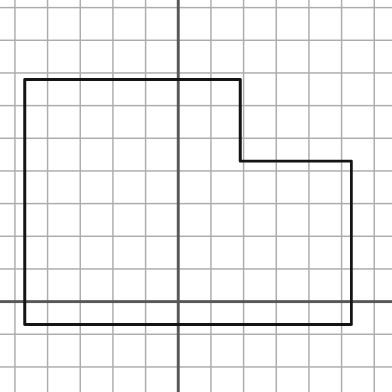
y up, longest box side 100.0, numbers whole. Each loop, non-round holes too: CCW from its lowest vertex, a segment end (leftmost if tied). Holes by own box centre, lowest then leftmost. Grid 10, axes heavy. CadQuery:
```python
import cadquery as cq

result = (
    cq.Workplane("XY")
    .moveTo(-47.0, -7.0)
    .lineTo(53.0, -7.0)
    .lineTo(53.0, 43.0)
    .lineTo(19.0, 43.0)
    .lineTo(19.0, 68.0)
    .lineTo(-47.0, 68.0)
    .close()
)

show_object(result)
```